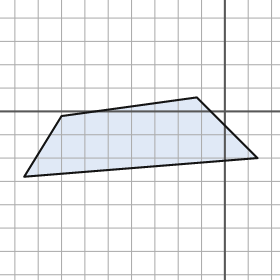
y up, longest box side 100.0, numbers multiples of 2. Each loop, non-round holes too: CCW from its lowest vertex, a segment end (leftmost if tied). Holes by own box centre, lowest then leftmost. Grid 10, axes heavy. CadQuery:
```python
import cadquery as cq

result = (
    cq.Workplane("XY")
    .moveTo(-86.0, -28.0)
    .lineTo(14.0, -20.0)
    .lineTo(-12.0, 6.0)
    .lineTo(-70.0, -2.0)
    .close()
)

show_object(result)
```